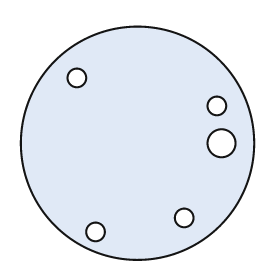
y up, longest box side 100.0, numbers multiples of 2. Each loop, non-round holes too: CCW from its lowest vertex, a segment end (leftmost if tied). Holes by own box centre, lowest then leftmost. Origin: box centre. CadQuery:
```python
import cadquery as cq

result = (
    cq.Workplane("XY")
    .moveTo(0.0, 0.0)
    .circle(50.0)
    .moveTo(-18.0, -38.0)
    .circle(4.0)
    .moveTo(20.0, -32.0)
    .circle(4.0)
    .moveTo(36.0, 0.0)
    .circle(6.0)
    .moveTo(34.0, 16.0)
    .circle(4.0)
    .moveTo(-26.0, 28.0)
    .circle(4.0)
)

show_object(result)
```